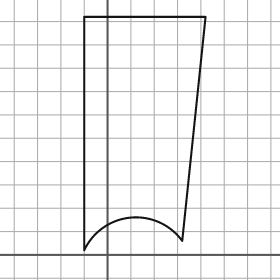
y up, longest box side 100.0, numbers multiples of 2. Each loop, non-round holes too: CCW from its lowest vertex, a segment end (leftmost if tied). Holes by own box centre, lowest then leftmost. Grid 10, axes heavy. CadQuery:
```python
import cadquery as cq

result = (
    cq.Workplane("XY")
    .moveTo(-10.0, 2.0)
    .threePointArc((10.0, 16.0), (32.0, 6.0))
    .lineTo(42.0, 102.0)
    .lineTo(-10.0, 102.0)
    .close()
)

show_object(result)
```